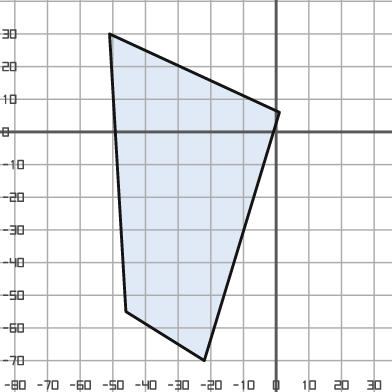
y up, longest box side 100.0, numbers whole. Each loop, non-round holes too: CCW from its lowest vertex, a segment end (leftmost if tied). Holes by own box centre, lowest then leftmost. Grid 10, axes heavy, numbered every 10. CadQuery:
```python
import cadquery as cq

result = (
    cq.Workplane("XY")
    .moveTo(-22.0, -70.0)
    .lineTo(1.0, 6.0)
    .lineTo(-51.0, 30.0)
    .lineTo(-46.0, -55.0)
    .close()
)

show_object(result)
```